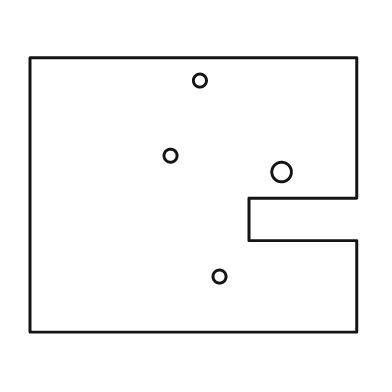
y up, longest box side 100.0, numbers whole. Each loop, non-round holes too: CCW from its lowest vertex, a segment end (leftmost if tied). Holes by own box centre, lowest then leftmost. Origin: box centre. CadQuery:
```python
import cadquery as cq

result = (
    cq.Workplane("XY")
    .moveTo(-50.0, -42.0)
    .lineTo(50.0, -42.0)
    .lineTo(50.0, -14.0)
    .lineTo(17.0, -14.0)
    .lineTo(17.0, -1.0)
    .lineTo(50.0, -1.0)
    .lineTo(50.0, 42.0)
    .lineTo(-50.0, 42.0)
    .close()
    .moveTo(8.0, -25.0)
    .circle(2.0)
    .moveTo(27.0, 7.0)
    .circle(3.0)
    .moveTo(-7.0, 12.0)
    .circle(2.0)
    .moveTo(2.0, 35.0)
    .circle(2.0)
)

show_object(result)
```